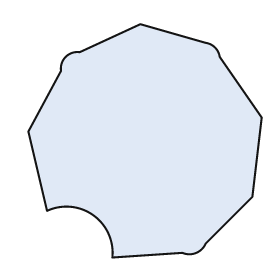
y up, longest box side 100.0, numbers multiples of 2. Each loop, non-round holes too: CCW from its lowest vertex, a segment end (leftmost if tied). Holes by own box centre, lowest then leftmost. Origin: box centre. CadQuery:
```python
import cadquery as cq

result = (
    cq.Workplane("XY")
    .moveTo(-14.0, -50.0)
    .lineTo(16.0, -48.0)
    .threePointArc((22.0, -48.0), (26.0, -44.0))
    .lineTo(46.0, -24.0)
    .lineTo(50.0, 10.0)
    .lineTo(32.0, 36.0)
    .threePointArc((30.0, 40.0), (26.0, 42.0))
    .lineTo(-2.0, 50.0)
    .lineTo(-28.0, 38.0)
    .threePointArc((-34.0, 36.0), (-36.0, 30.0))
    .lineTo(-50.0, 4.0)
    .lineTo(-42.0, -30.0)
    .threePointArc((-22.0, -32.0), (-14.0, -50.0))
    .close()
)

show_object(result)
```